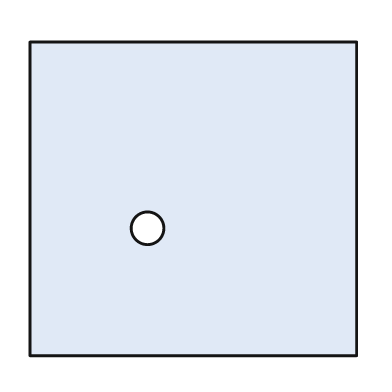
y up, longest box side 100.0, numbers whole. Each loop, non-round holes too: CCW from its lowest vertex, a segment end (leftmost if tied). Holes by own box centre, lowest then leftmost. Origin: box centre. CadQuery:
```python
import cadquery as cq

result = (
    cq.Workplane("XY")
    .moveTo(-50.0, -48.0)
    .lineTo(50.0, -48.0)
    .lineTo(50.0, 48.0)
    .lineTo(-50.0, 48.0)
    .close()
    .moveTo(-14.0, -9.0)
    .circle(5.0)
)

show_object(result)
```